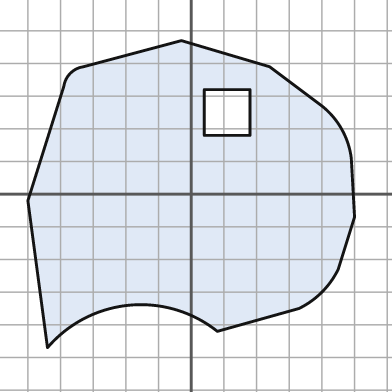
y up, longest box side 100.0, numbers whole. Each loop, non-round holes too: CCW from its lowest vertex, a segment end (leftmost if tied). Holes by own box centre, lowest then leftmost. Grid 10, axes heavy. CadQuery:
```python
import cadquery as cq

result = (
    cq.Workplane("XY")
    .moveTo(-44.0, -47.0)
    .threePointArc((-19.0, -34.0), (8.0, -42.0))
    .lineTo(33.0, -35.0)
    .threePointArc((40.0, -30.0), (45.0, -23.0))
    .lineTo(50.0, -7.0)
    .lineTo(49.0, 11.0)
    .threePointArc((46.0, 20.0), (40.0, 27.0))
    .lineTo(24.0, 39.0)
    .lineTo(-3.0, 47.0)
    .lineTo(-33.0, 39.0)
    .threePointArc((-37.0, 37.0), (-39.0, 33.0))
    .lineTo(-50.0, -2.0)
    .close()
    .moveTo(4.0, 18.0)
    .lineTo(18.0, 18.0)
    .lineTo(18.0, 32.0)
    .lineTo(4.0, 32.0)
    .close()
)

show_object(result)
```